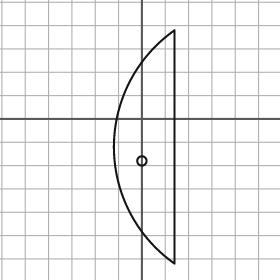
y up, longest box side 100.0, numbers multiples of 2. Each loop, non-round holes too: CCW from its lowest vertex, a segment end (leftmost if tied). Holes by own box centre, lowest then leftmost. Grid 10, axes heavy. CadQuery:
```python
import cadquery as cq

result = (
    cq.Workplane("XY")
    .moveTo(14.0, -62.0)
    .lineTo(14.0, 38.0)
    .threePointArc((-12.0, -12.0), (14.0, -62.0))
    .close()
    .moveTo(0.0, -18.0)
    .circle(2.0)
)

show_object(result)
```